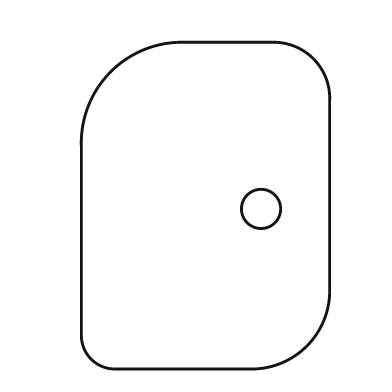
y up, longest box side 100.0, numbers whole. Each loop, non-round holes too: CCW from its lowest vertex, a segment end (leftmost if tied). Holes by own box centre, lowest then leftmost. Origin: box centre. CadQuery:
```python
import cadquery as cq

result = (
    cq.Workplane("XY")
    .moveTo(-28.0, -50.0)
    .lineTo(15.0, -50.0)
    .threePointArc((31.0, -43.0), (38.0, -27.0))
    .lineTo(38.0, 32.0)
    .threePointArc((33.0, 45.0), (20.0, 50.0))
    .lineTo(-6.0, 50.0)
    .threePointArc((-29.0, 41.0), (-38.0, 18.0))
    .lineTo(-38.0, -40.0)
    .threePointArc((-35.0, -47.0), (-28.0, -50.0))
    .close()
    .moveTo(17.0, -1.0)
    .circle(6.0)
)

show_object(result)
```